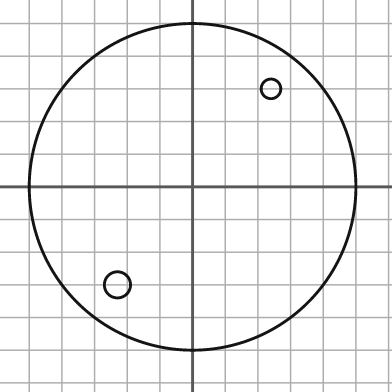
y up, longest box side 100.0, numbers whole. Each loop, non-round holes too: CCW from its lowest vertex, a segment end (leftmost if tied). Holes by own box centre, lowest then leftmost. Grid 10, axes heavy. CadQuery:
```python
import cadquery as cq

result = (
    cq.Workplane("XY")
    .moveTo(0.0, 0.0)
    .circle(50.0)
    .moveTo(-23.0, -30.0)
    .circle(4.0)
    .moveTo(24.0, 30.0)
    .circle(3.0)
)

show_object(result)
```